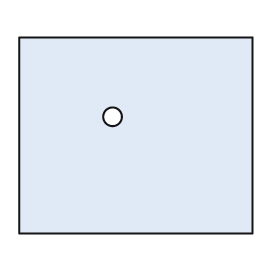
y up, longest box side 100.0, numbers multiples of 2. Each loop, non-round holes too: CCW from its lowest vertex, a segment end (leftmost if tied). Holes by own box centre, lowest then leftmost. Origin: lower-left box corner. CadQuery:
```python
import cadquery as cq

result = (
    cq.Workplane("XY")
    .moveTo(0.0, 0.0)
    .lineTo(100.0, 0.0)
    .lineTo(100.0, 84.0)
    .lineTo(0.0, 84.0)
    .close()
    .moveTo(40.0, 50.0)
    .circle(4.0)
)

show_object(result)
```